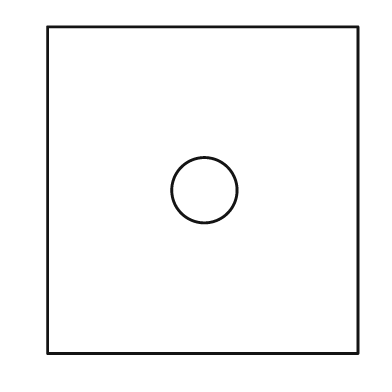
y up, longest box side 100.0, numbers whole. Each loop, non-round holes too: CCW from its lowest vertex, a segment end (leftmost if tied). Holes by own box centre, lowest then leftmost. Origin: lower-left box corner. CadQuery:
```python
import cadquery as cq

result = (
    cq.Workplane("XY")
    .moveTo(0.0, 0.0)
    .lineTo(95.0, 0.0)
    .lineTo(95.0, 100.0)
    .lineTo(0.0, 100.0)
    .close()
    .moveTo(48.0, 50.0)
    .circle(10.0)
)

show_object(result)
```